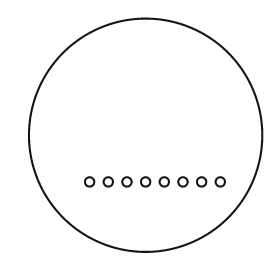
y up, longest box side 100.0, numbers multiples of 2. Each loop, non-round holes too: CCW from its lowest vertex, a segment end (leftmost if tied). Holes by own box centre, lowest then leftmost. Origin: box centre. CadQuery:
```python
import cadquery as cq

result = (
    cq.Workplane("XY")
    .moveTo(0.0, 0.0)
    .circle(50.0)
    .moveTo(-24.0, -20.0)
    .circle(2.0)
    .moveTo(-16.0, -20.0)
    .circle(2.0)
    .moveTo(-8.0, -20.0)
    .circle(2.0)
    .moveTo(0.0, -20.0)
    .circle(2.0)
    .moveTo(8.0, -20.0)
    .circle(2.0)
    .moveTo(16.0, -20.0)
    .circle(2.0)
    .moveTo(24.0, -20.0)
    .circle(2.0)
    .moveTo(32.0, -20.0)
    .circle(2.0)
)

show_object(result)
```